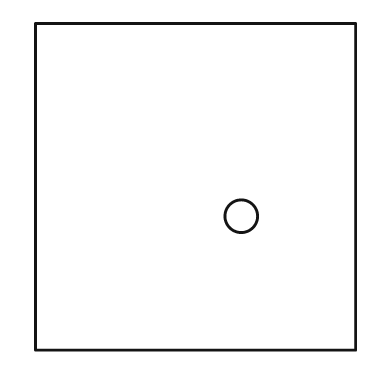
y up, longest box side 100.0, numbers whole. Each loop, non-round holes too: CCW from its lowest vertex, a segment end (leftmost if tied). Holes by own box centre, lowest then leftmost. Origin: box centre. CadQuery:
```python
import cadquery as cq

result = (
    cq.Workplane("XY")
    .moveTo(-49.0, -50.0)
    .lineTo(49.0, -50.0)
    .lineTo(49.0, 50.0)
    .lineTo(-49.0, 50.0)
    .close()
    .moveTo(14.0, -9.0)
    .circle(5.0)
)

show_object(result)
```